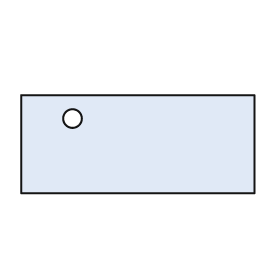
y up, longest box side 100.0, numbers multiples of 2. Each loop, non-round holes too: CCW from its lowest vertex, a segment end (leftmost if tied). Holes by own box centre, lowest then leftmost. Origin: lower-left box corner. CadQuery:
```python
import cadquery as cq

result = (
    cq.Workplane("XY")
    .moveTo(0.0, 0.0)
    .lineTo(100.0, 0.0)
    .lineTo(100.0, 42.0)
    .lineTo(0.0, 42.0)
    .close()
    .moveTo(22.0, 32.0)
    .circle(4.0)
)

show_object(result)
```